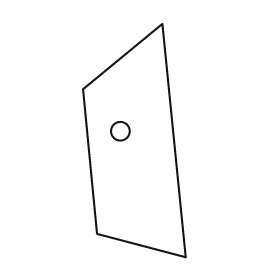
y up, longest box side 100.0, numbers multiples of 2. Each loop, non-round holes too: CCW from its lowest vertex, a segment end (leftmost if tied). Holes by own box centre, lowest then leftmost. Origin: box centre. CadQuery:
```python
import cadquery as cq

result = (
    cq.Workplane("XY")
    .moveTo(22.0, -50.0)
    .lineTo(12.0, 50.0)
    .lineTo(-22.0, 22.0)
    .lineTo(-16.0, -40.0)
    .close()
    .moveTo(-6.0, 4.0)
    .circle(4.0)
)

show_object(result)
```